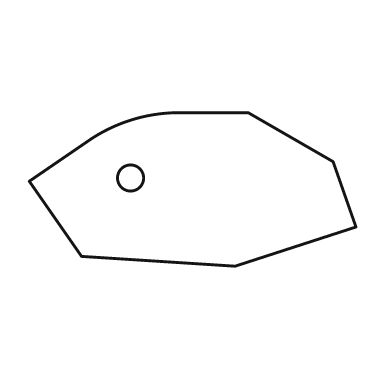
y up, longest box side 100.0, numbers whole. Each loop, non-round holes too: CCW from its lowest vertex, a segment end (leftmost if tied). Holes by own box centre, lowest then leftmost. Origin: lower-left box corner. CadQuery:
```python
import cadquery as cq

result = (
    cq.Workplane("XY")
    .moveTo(63.0, 0.0)
    .lineTo(100.0, 12.0)
    .lineTo(93.0, 32.0)
    .lineTo(67.0, 47.0)
    .lineTo(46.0, 47.0)
    .threePointArc((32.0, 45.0), (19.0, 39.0))
    .lineTo(0.0, 26.0)
    .lineTo(16.0, 3.0)
    .close()
    .moveTo(31.0, 27.0)
    .circle(4.0)
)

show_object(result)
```